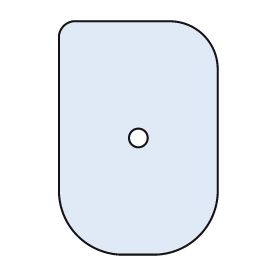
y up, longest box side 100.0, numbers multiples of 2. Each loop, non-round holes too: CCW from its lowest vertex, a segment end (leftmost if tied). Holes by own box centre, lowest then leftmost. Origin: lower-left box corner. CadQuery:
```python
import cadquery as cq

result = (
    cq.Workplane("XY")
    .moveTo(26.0, 0.0)
    .lineTo(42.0, 0.0)
    .threePointArc((60.0, 8.0), (68.0, 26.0))
    .lineTo(68.0, 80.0)
    .threePointArc((62.0, 94.0), (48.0, 100.0))
    .lineTo(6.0, 100.0)
    .threePointArc((2.0, 98.0), (0.0, 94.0))
    .lineTo(0.0, 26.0)
    .threePointArc((8.0, 8.0), (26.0, 0.0))
    .close()
    .moveTo(34.0, 50.0)
    .circle(4.0)
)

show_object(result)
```